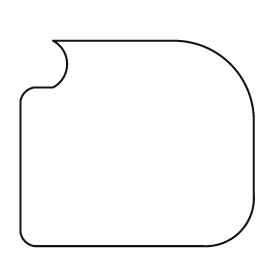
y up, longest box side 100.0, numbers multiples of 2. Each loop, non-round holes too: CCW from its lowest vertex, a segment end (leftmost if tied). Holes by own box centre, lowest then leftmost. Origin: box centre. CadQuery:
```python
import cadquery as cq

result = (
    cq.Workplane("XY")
    .moveTo(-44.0, -44.0)
    .lineTo(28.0, -44.0)
    .threePointArc((44.0, -38.0), (50.0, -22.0))
    .lineTo(50.0, 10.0)
    .threePointArc((40.0, 34.0), (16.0, 44.0))
    .lineTo(-36.0, 44.0)
    .threePointArc((-30.0, 34.0), (-36.0, 24.0))
    .lineTo(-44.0, 24.0)
    .threePointArc((-48.0, 22.0), (-50.0, 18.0))
    .lineTo(-50.0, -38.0)
    .threePointArc((-48.0, -42.0), (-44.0, -44.0))
    .close()
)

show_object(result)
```